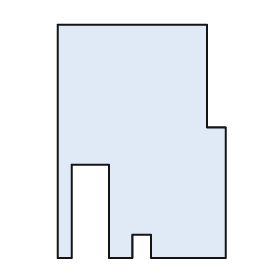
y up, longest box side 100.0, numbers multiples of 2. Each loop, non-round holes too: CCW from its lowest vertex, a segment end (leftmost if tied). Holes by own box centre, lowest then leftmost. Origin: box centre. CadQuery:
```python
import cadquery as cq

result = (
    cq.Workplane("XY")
    .moveTo(-36.0, -50.0)
    .lineTo(-30.0, -50.0)
    .lineTo(-30.0, -10.0)
    .lineTo(-14.0, -10.0)
    .lineTo(-14.0, -50.0)
    .lineTo(-4.0, -50.0)
    .lineTo(-4.0, -40.0)
    .lineTo(4.0, -40.0)
    .lineTo(4.0, -50.0)
    .lineTo(36.0, -50.0)
    .lineTo(36.0, 6.0)
    .lineTo(28.0, 6.0)
    .lineTo(28.0, 50.0)
    .lineTo(-36.0, 50.0)
    .close()
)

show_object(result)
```